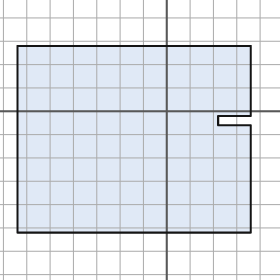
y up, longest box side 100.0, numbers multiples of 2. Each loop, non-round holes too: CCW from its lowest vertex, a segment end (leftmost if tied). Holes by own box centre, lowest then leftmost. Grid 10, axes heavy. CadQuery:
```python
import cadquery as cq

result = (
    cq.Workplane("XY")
    .moveTo(-64.0, -52.0)
    .lineTo(36.0, -52.0)
    .lineTo(36.0, -6.0)
    .lineTo(22.0, -6.0)
    .lineTo(22.0, -2.0)
    .lineTo(36.0, -2.0)
    .lineTo(36.0, 28.0)
    .lineTo(-64.0, 28.0)
    .close()
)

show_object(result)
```